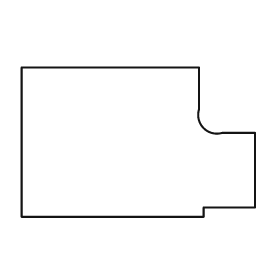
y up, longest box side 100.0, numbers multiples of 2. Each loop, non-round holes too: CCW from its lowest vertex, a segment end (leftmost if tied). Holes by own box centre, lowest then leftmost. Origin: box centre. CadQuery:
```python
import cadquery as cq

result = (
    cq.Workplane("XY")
    .moveTo(-50.0, -32.0)
    .lineTo(28.0, -32.0)
    .lineTo(28.0, -28.0)
    .lineTo(50.0, -28.0)
    .lineTo(50.0, 4.0)
    .lineTo(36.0, 4.0)
    .threePointArc((28.0, 6.0), (26.0, 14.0))
    .lineTo(26.0, 32.0)
    .lineTo(-50.0, 32.0)
    .close()
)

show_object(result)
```